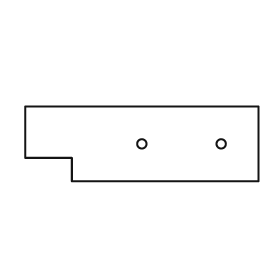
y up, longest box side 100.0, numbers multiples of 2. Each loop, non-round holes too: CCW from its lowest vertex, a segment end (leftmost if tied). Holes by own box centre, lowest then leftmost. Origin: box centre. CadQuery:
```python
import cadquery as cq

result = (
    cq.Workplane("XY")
    .moveTo(-30.0, -16.0)
    .lineTo(50.0, -16.0)
    .lineTo(50.0, 16.0)
    .lineTo(-50.0, 16.0)
    .lineTo(-50.0, -6.0)
    .lineTo(-30.0, -6.0)
    .close()
    .moveTo(0.0, 0.0)
    .circle(2.0)
    .moveTo(34.0, 0.0)
    .circle(2.0)
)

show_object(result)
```